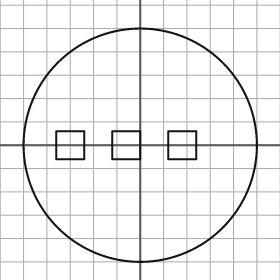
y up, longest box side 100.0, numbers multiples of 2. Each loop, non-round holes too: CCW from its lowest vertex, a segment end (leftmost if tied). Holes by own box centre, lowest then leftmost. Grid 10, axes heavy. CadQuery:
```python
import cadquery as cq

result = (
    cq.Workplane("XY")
    .moveTo(0.0, 0.0)
    .circle(50.0)
    .moveTo(-36.0, -6.0)
    .lineTo(-24.0, -6.0)
    .lineTo(-24.0, 6.0)
    .lineTo(-36.0, 6.0)
    .close()
    .moveTo(-12.0, -6.0)
    .lineTo(0.0, -6.0)
    .lineTo(0.0, 6.0)
    .lineTo(-12.0, 6.0)
    .close()
    .moveTo(12.0, -6.0)
    .lineTo(24.0, -6.0)
    .lineTo(24.0, 6.0)
    .lineTo(12.0, 6.0)
    .close()
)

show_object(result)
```